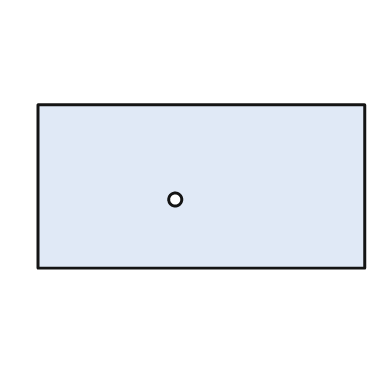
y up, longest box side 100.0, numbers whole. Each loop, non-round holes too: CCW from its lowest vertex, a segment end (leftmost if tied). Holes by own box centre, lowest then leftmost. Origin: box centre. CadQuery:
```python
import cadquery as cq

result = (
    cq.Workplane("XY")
    .moveTo(-50.0, -25.0)
    .lineTo(50.0, -25.0)
    .lineTo(50.0, 25.0)
    .lineTo(-50.0, 25.0)
    .close()
    .moveTo(-8.0, -4.0)
    .circle(2.0)
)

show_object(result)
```